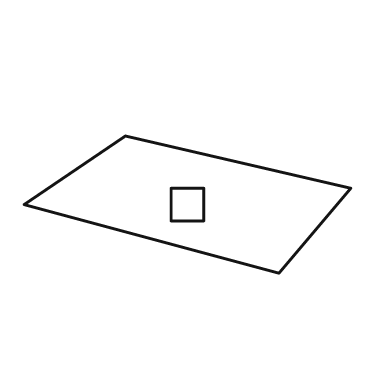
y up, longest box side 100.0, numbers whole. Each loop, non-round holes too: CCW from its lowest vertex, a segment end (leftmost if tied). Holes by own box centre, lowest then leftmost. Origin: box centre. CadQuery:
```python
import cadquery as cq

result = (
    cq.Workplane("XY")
    .moveTo(28.0, -21.0)
    .lineTo(50.0, 5.0)
    .lineTo(-19.0, 21.0)
    .lineTo(-50.0, 0.0)
    .close()
    .moveTo(-5.0, -5.0)
    .lineTo(5.0, -5.0)
    .lineTo(5.0, 5.0)
    .lineTo(-5.0, 5.0)
    .close()
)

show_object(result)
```